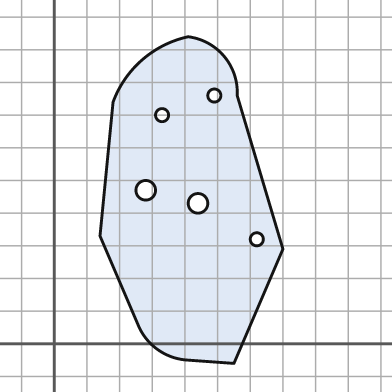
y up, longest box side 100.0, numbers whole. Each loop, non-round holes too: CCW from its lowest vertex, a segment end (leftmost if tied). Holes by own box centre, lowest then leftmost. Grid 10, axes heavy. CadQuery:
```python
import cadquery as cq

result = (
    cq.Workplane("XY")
    .moveTo(55.0, -6.0)
    .lineTo(70.0, 29.0)
    .lineTo(56.0, 76.0)
    .threePointArc((52.0, 88.0), (41.0, 94.0))
    .threePointArc((27.0, 87.0), (18.0, 74.0))
    .lineTo(14.0, 33.0)
    .lineTo(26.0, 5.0)
    .threePointArc((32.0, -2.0), (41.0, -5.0))
    .close()
    .moveTo(62.0, 32.0)
    .circle(2.0)
    .moveTo(44.0, 43.0)
    .circle(3.0)
    .moveTo(28.0, 47.0)
    .circle(3.0)
    .moveTo(33.0, 70.0)
    .circle(2.0)
    .moveTo(49.0, 76.0)
    .circle(2.0)
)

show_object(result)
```